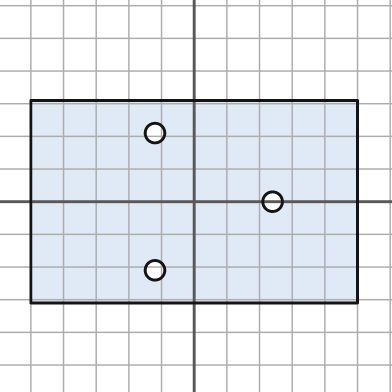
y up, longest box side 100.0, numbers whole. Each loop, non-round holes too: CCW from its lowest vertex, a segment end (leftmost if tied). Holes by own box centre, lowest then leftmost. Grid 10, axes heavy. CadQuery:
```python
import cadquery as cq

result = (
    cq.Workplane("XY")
    .moveTo(-50.0, -31.0)
    .lineTo(50.0, -31.0)
    .lineTo(50.0, 31.0)
    .lineTo(-50.0, 31.0)
    .close()
    .moveTo(-12.0, -21.0)
    .circle(3.0)
    .moveTo(24.0, 0.0)
    .circle(3.0)
    .moveTo(-12.0, 21.0)
    .circle(3.0)
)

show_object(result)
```